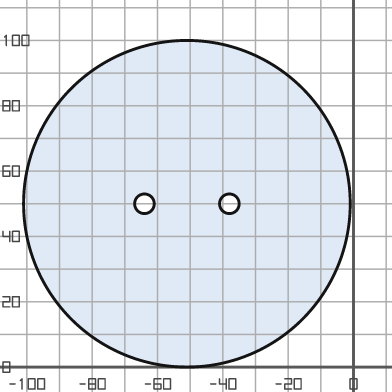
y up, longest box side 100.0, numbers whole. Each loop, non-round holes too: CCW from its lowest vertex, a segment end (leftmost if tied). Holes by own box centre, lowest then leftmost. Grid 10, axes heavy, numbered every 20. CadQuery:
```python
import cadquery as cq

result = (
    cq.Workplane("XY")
    .moveTo(-51.0, 50.0)
    .circle(50.0)
    .moveTo(-64.0, 50.0)
    .circle(3.0)
    .moveTo(-38.0, 50.0)
    .circle(3.0)
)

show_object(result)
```